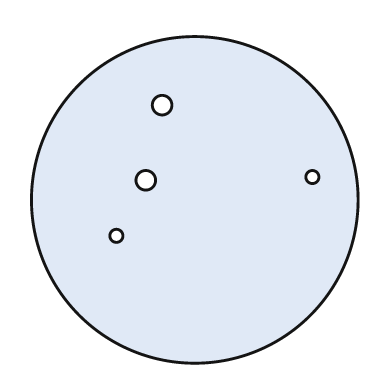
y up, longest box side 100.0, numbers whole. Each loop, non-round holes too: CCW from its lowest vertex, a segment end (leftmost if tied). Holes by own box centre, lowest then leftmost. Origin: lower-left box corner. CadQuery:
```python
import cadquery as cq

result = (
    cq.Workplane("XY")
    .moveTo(50.0, 50.0)
    .circle(50.0)
    .moveTo(26.0, 39.0)
    .circle(2.0)
    .moveTo(35.0, 56.0)
    .circle(3.0)
    .moveTo(86.0, 57.0)
    .circle(2.0)
    .moveTo(40.0, 79.0)
    .circle(3.0)
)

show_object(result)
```